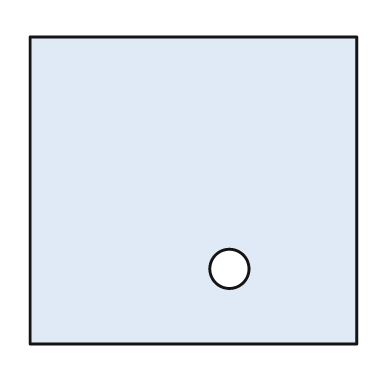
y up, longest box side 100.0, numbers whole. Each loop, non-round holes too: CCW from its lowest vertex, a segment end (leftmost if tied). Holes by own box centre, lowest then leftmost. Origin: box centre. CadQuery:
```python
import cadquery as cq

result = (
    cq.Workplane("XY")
    .moveTo(-50.0, -47.0)
    .lineTo(50.0, -47.0)
    .lineTo(50.0, 47.0)
    .lineTo(-50.0, 47.0)
    .close()
    .moveTo(11.0, -24.0)
    .circle(6.0)
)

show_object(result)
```